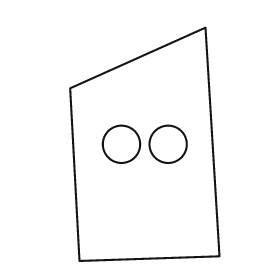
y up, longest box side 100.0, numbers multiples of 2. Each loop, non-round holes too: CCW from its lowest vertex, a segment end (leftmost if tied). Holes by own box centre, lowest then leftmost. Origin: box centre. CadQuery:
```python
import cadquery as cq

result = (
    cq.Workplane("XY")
    .moveTo(-28.0, -50.0)
    .lineTo(32.0, -48.0)
    .lineTo(26.0, 50.0)
    .lineTo(-32.0, 24.0)
    .close()
    .moveTo(-10.0, 0.0)
    .circle(8.0)
    .moveTo(10.0, 0.0)
    .circle(8.0)
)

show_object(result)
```